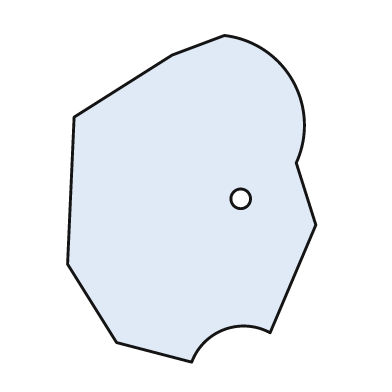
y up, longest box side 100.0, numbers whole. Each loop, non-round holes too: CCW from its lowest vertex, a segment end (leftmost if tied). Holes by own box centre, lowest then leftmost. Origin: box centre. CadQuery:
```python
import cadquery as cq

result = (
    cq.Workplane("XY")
    .moveTo(0.0, -50.0)
    .threePointArc((10.0, -40.0), (24.0, -41.0))
    .lineTo(38.0, -8.0)
    .lineTo(32.0, 11.0)
    .threePointArc((31.0, 36.0), (10.0, 50.0))
    .lineTo(-6.0, 44.0)
    .lineTo(-36.0, 25.0)
    .lineTo(-38.0, -20.0)
    .lineTo(-23.0, -44.0)
    .close()
    .moveTo(15.0, 0.0)
    .circle(3.0)
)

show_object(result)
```